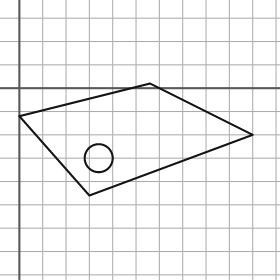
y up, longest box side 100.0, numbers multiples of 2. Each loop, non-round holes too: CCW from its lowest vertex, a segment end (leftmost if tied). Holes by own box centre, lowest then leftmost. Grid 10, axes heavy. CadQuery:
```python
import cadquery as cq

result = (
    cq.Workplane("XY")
    .moveTo(30.0, -46.0)
    .lineTo(100.0, -20.0)
    .lineTo(56.0, 2.0)
    .lineTo(0.0, -12.0)
    .close()
    .moveTo(34.0, -30.0)
    .circle(6.0)
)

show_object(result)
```